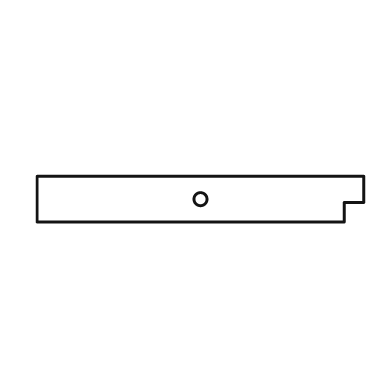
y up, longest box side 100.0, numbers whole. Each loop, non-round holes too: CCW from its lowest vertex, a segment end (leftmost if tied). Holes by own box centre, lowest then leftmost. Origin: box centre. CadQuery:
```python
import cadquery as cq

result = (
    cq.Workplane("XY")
    .moveTo(-50.0, -7.0)
    .lineTo(44.0, -7.0)
    .lineTo(44.0, -1.0)
    .lineTo(50.0, -1.0)
    .lineTo(50.0, 7.0)
    .lineTo(-50.0, 7.0)
    .close()
    .moveTo(0.0, 0.0)
    .circle(2.0)
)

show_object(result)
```